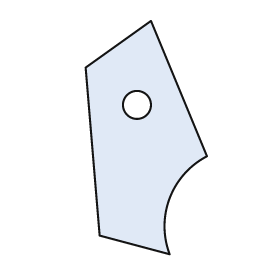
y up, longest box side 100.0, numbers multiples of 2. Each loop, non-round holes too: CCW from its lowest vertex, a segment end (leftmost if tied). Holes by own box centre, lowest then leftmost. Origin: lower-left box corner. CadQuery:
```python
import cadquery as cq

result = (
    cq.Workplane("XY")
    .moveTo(36.0, 0.0)
    .threePointArc((36.0, 24.0), (52.0, 42.0))
    .lineTo(28.0, 100.0)
    .lineTo(0.0, 80.0)
    .lineTo(6.0, 8.0)
    .close()
    .moveTo(22.0, 64.0)
    .circle(6.0)
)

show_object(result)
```